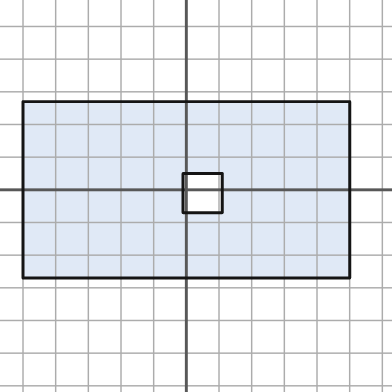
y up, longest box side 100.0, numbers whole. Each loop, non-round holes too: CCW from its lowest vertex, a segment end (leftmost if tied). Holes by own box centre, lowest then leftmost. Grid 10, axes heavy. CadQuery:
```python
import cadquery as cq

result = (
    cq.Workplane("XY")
    .moveTo(-50.0, -27.0)
    .lineTo(50.0, -27.0)
    .lineTo(50.0, 27.0)
    .lineTo(-50.0, 27.0)
    .close()
    .moveTo(-1.0, -7.0)
    .lineTo(11.0, -7.0)
    .lineTo(11.0, 5.0)
    .lineTo(-1.0, 5.0)
    .close()
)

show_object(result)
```